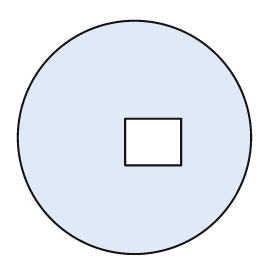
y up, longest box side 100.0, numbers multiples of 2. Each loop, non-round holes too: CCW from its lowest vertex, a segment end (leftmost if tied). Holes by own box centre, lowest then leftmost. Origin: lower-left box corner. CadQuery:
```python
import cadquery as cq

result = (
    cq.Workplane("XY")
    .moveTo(50.0, 50.0)
    .circle(50.0)
    .moveTo(46.0, 38.0)
    .lineTo(70.0, 38.0)
    .lineTo(70.0, 58.0)
    .lineTo(46.0, 58.0)
    .close()
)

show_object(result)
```